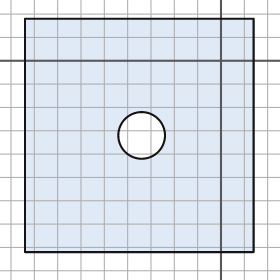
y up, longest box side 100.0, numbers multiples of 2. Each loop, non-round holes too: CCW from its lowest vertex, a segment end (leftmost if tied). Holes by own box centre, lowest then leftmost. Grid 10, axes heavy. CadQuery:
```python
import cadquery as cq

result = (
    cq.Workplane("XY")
    .moveTo(-84.0, -82.0)
    .lineTo(14.0, -82.0)
    .lineTo(14.0, 18.0)
    .lineTo(-84.0, 18.0)
    .close()
    .moveTo(-34.0, -32.0)
    .circle(10.0)
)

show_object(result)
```